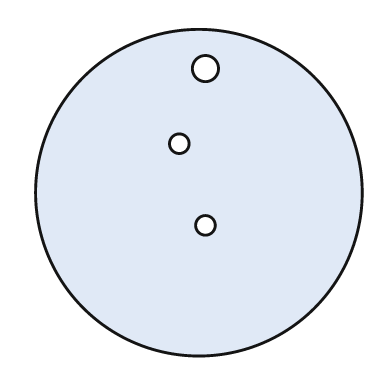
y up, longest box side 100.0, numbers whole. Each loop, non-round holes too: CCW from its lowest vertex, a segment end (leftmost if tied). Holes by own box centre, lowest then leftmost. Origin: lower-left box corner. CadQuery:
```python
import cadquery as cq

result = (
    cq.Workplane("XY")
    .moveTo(50.0, 50.0)
    .circle(50.0)
    .moveTo(52.0, 40.0)
    .circle(3.0)
    .moveTo(44.0, 65.0)
    .circle(3.0)
    .moveTo(52.0, 88.0)
    .circle(4.0)
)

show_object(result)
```